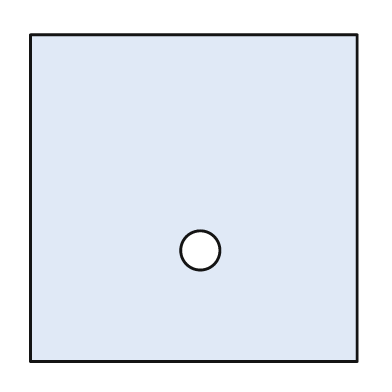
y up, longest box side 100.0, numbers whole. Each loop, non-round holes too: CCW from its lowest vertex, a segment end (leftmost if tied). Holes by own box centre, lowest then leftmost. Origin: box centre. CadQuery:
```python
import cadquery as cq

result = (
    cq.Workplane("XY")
    .moveTo(-50.0, -50.0)
    .lineTo(50.0, -50.0)
    .lineTo(50.0, 50.0)
    .lineTo(-50.0, 50.0)
    .close()
    .moveTo(2.0, -16.0)
    .circle(6.0)
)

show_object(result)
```